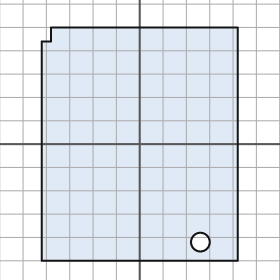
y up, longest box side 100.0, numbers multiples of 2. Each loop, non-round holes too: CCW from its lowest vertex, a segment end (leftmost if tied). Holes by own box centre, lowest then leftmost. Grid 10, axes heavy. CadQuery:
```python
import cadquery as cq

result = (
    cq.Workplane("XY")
    .moveTo(-42.0, -50.0)
    .lineTo(42.0, -50.0)
    .lineTo(42.0, 50.0)
    .lineTo(-38.0, 50.0)
    .lineTo(-38.0, 44.0)
    .lineTo(-42.0, 44.0)
    .close()
    .moveTo(26.0, -42.0)
    .circle(4.0)
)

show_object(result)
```